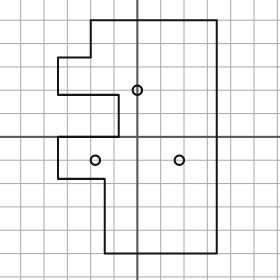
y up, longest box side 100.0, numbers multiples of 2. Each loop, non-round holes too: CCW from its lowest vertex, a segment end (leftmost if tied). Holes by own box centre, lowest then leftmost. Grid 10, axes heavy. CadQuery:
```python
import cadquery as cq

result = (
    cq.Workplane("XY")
    .moveTo(-14.0, -50.0)
    .lineTo(34.0, -50.0)
    .lineTo(34.0, 50.0)
    .lineTo(-20.0, 50.0)
    .lineTo(-20.0, 34.0)
    .lineTo(-34.0, 34.0)
    .lineTo(-34.0, 18.0)
    .lineTo(-8.0, 18.0)
    .lineTo(-8.0, 0.0)
    .lineTo(-34.0, 0.0)
    .lineTo(-34.0, -18.0)
    .lineTo(-14.0, -18.0)
    .close()
    .moveTo(-18.0, -10.0)
    .circle(2.0)
    .moveTo(18.0, -10.0)
    .circle(2.0)
    .moveTo(0.0, 20.0)
    .circle(2.0)
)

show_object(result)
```